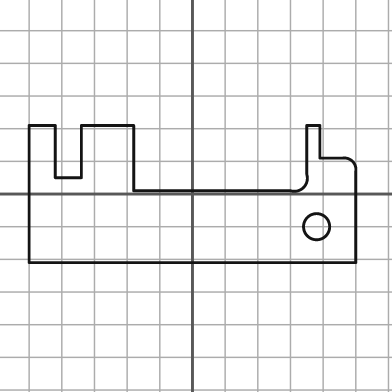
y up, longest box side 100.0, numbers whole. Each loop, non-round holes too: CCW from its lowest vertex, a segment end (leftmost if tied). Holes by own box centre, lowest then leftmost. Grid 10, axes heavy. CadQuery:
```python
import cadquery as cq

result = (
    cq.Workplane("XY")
    .moveTo(-50.0, -21.0)
    .lineTo(50.0, -21.0)
    .lineTo(50.0, 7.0)
    .threePointArc((49.0, 10.0), (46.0, 11.0))
    .lineTo(39.0, 11.0)
    .lineTo(39.0, 21.0)
    .lineTo(35.0, 21.0)
    .lineTo(35.0, 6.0)
    .threePointArc((34.0, 2.0), (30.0, 1.0))
    .lineTo(-18.0, 1.0)
    .lineTo(-18.0, 21.0)
    .lineTo(-34.0, 21.0)
    .lineTo(-34.0, 5.0)
    .lineTo(-42.0, 5.0)
    .lineTo(-42.0, 21.0)
    .lineTo(-50.0, 21.0)
    .close()
    .moveTo(38.0, -10.0)
    .circle(4.0)
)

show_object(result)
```